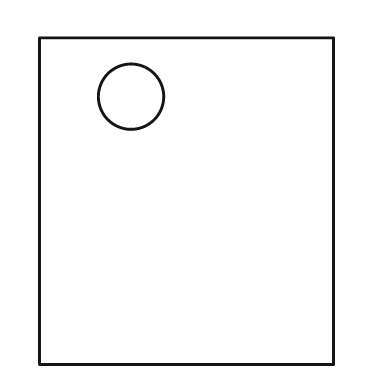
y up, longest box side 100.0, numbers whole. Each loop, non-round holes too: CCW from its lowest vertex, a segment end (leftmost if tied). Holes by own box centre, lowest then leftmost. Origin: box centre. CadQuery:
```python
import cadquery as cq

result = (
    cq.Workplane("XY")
    .moveTo(-45.0, -50.0)
    .lineTo(45.0, -50.0)
    .lineTo(45.0, 50.0)
    .lineTo(-45.0, 50.0)
    .close()
    .moveTo(-17.0, 32.0)
    .circle(10.0)
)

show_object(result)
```